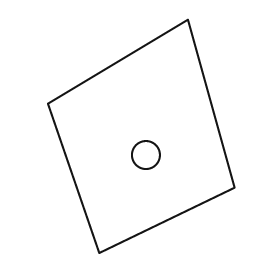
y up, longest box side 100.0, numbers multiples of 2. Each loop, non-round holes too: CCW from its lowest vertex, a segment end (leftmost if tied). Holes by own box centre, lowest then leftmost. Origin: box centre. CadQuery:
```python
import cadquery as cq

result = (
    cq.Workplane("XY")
    .moveTo(-18.0, -50.0)
    .lineTo(40.0, -22.0)
    .lineTo(20.0, 50.0)
    .lineTo(-40.0, 14.0)
    .close()
    .moveTo(2.0, -8.0)
    .circle(6.0)
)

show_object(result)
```